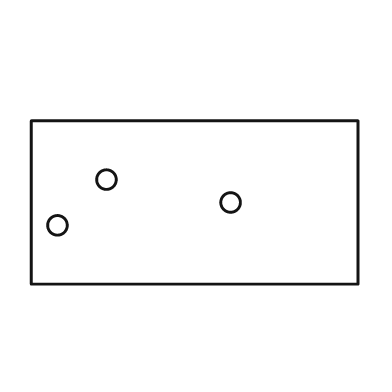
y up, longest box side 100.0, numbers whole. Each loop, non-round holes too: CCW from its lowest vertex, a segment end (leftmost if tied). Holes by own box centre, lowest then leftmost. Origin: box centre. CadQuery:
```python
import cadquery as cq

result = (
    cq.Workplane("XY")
    .moveTo(-50.0, -25.0)
    .lineTo(50.0, -25.0)
    .lineTo(50.0, 25.0)
    .lineTo(-50.0, 25.0)
    .close()
    .moveTo(-42.0, -7.0)
    .circle(3.0)
    .moveTo(11.0, 0.0)
    .circle(3.0)
    .moveTo(-27.0, 7.0)
    .circle(3.0)
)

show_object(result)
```